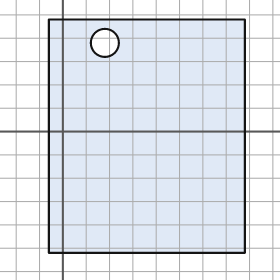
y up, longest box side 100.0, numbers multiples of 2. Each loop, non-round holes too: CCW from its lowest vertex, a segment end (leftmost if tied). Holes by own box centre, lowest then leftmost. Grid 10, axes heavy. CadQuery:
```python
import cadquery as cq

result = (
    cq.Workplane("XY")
    .moveTo(-6.0, -52.0)
    .lineTo(78.0, -52.0)
    .lineTo(78.0, 48.0)
    .lineTo(-6.0, 48.0)
    .close()
    .moveTo(18.0, 38.0)
    .circle(6.0)
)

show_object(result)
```